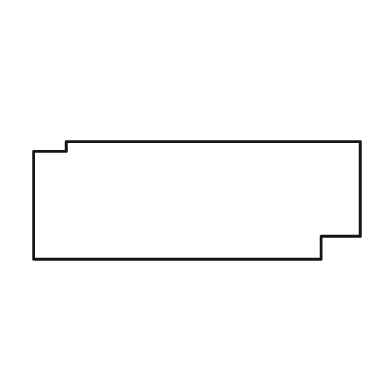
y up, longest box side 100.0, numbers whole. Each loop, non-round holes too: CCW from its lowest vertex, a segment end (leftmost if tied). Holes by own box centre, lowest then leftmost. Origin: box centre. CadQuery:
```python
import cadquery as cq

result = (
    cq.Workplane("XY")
    .moveTo(-50.0, -18.0)
    .lineTo(38.0, -18.0)
    .lineTo(38.0, -11.0)
    .lineTo(50.0, -11.0)
    .lineTo(50.0, 18.0)
    .lineTo(-40.0, 18.0)
    .lineTo(-40.0, 15.0)
    .lineTo(-50.0, 15.0)
    .close()
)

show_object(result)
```